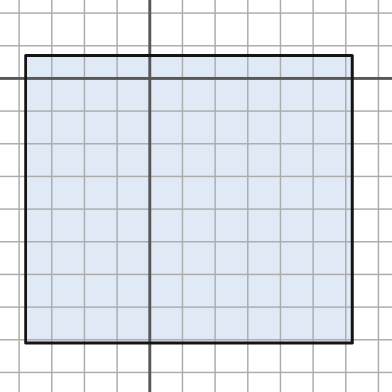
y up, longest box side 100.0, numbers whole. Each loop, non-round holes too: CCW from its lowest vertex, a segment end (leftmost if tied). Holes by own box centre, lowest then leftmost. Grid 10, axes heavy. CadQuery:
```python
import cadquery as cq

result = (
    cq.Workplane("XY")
    .moveTo(-38.0, -81.0)
    .lineTo(62.0, -81.0)
    .lineTo(62.0, 7.0)
    .lineTo(-38.0, 7.0)
    .close()
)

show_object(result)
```